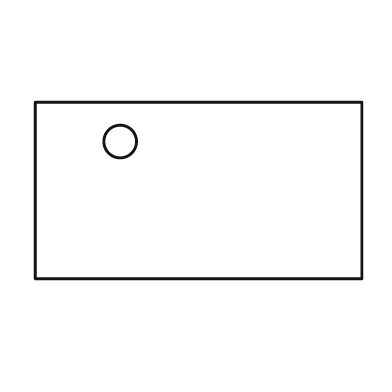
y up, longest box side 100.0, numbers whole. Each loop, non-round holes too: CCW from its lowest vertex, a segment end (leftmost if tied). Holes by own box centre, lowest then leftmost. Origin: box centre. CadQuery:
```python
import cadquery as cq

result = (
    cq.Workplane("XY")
    .moveTo(-50.0, -27.0)
    .lineTo(50.0, -27.0)
    .lineTo(50.0, 27.0)
    .lineTo(-50.0, 27.0)
    .close()
    .moveTo(-24.0, 15.0)
    .circle(5.0)
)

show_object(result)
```